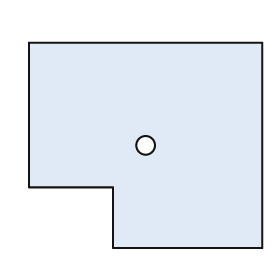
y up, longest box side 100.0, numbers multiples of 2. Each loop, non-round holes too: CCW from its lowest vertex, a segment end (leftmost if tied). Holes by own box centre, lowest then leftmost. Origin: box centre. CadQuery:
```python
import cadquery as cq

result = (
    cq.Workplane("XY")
    .moveTo(-14.0, -44.0)
    .lineTo(50.0, -44.0)
    .lineTo(50.0, 44.0)
    .lineTo(-50.0, 44.0)
    .lineTo(-50.0, -18.0)
    .lineTo(-14.0, -18.0)
    .close()
    .moveTo(0.0, 0.0)
    .circle(4.0)
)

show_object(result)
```